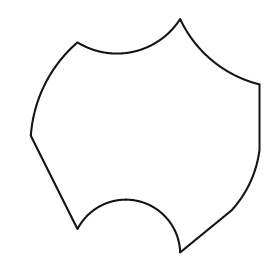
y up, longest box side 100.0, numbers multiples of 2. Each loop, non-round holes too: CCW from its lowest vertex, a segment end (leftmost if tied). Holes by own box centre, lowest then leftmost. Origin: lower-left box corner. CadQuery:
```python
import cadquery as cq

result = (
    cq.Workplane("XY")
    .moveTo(64.0, 0.0)
    .lineTo(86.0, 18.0)
    .threePointArc((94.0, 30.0), (98.0, 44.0))
    .lineTo(98.0, 72.0)
    .threePointArc((78.0, 82.0), (64.0, 100.0))
    .threePointArc((44.0, 86.0), (20.0, 90.0))
    .threePointArc((6.0, 72.0), (0.0, 50.0))
    .lineTo(20.0, 10.0)
    .threePointArc((46.0, 22.0), (64.0, 0.0))
    .close()
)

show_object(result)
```